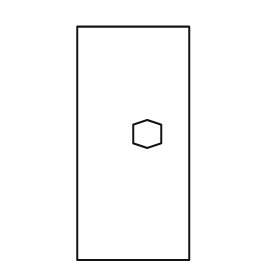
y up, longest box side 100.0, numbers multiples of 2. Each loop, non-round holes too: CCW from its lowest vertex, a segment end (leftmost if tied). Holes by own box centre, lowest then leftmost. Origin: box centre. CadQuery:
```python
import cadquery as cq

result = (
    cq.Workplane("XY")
    .moveTo(-24.0, -50.0)
    .lineTo(24.0, -50.0)
    .lineTo(24.0, 50.0)
    .lineTo(-24.0, 50.0)
    .close()
    .moveTo(6.0, -2.0)
    .lineTo(12.0, 0.0)
    .lineTo(12.0, 8.0)
    .lineTo(6.0, 10.0)
    .lineTo(0.0, 8.0)
    .lineTo(0.0, 0.0)
    .close()
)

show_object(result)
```